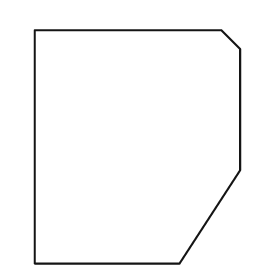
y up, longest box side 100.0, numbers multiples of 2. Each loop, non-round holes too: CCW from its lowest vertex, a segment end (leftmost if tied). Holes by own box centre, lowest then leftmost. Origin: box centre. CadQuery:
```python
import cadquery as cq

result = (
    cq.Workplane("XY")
    .moveTo(-44.0, -50.0)
    .lineTo(18.0, -50.0)
    .lineTo(44.0, -10.0)
    .lineTo(44.0, 42.0)
    .lineTo(36.0, 50.0)
    .lineTo(-44.0, 50.0)
    .close()
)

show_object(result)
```